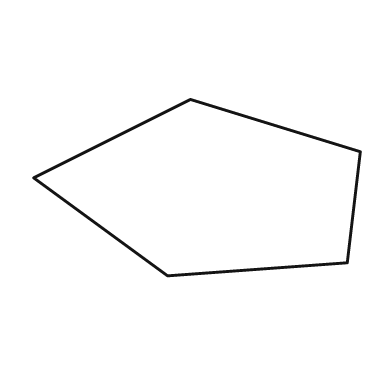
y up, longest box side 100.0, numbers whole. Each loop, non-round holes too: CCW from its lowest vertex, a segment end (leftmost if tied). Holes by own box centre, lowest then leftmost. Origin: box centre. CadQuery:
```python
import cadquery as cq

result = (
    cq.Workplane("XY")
    .moveTo(-9.0, -27.0)
    .lineTo(46.0, -23.0)
    .lineTo(50.0, 11.0)
    .lineTo(-2.0, 27.0)
    .lineTo(-50.0, 3.0)
    .close()
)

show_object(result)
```